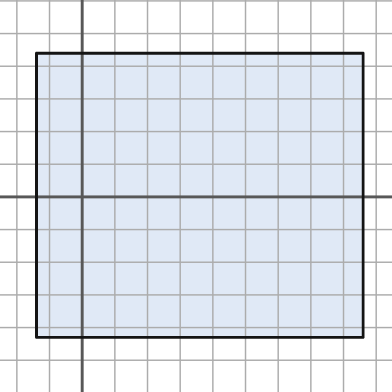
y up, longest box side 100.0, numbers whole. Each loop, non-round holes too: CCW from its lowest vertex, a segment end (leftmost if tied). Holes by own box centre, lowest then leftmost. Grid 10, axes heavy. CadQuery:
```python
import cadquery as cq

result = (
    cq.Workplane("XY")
    .moveTo(-14.0, -43.0)
    .lineTo(86.0, -43.0)
    .lineTo(86.0, 44.0)
    .lineTo(-14.0, 44.0)
    .close()
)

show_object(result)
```